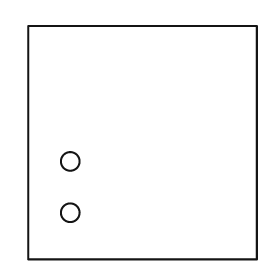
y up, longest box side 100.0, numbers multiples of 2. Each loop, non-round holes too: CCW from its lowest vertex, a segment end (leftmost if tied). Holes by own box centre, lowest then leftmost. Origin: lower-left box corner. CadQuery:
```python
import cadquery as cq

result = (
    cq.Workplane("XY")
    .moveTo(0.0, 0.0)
    .lineTo(98.0, 0.0)
    .lineTo(98.0, 100.0)
    .lineTo(0.0, 100.0)
    .close()
    .moveTo(18.0, 20.0)
    .circle(4.0)
    .moveTo(18.0, 42.0)
    .circle(4.0)
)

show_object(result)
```